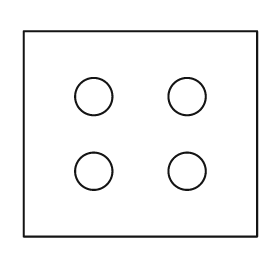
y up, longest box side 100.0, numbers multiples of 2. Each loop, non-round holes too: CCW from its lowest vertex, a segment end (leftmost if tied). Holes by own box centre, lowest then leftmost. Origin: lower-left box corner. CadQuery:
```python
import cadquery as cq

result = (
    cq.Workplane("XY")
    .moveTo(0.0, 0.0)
    .lineTo(100.0, 0.0)
    .lineTo(100.0, 88.0)
    .lineTo(0.0, 88.0)
    .close()
    .moveTo(30.0, 28.0)
    .circle(8.0)
    .moveTo(70.0, 28.0)
    .circle(8.0)
    .moveTo(30.0, 60.0)
    .circle(8.0)
    .moveTo(70.0, 60.0)
    .circle(8.0)
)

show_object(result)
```